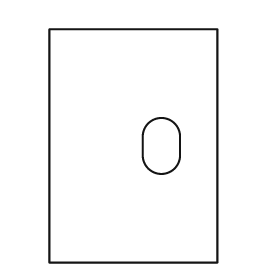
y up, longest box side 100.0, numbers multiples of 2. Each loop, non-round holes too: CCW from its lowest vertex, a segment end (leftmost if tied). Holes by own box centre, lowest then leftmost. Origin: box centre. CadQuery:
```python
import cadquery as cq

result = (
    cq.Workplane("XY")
    .moveTo(-36.0, -50.0)
    .lineTo(36.0, -50.0)
    .lineTo(36.0, 50.0)
    .lineTo(-36.0, 50.0)
    .close()
    .moveTo(4.0, -4.0)
    .threePointArc((12.0, -12.0), (20.0, -4.0))
    .lineTo(20.0, 4.0)
    .threePointArc((12.0, 12.0), (4.0, 4.0))
    .close()
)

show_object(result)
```